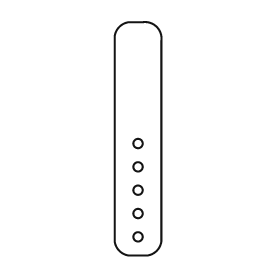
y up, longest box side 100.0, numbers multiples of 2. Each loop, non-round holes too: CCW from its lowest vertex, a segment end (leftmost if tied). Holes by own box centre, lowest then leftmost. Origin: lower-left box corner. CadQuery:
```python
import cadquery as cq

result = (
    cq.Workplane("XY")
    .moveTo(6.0, 0.0)
    .lineTo(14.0, 0.0)
    .threePointArc((18.0, 2.0), (20.0, 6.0))
    .lineTo(20.0, 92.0)
    .threePointArc((18.0, 98.0), (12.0, 100.0))
    .lineTo(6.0, 100.0)
    .threePointArc((2.0, 98.0), (0.0, 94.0))
    .lineTo(0.0, 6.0)
    .threePointArc((2.0, 2.0), (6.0, 0.0))
    .close()
    .moveTo(10.0, 8.0)
    .circle(2.0)
    .moveTo(10.0, 18.0)
    .circle(2.0)
    .moveTo(10.0, 28.0)
    .circle(2.0)
    .moveTo(10.0, 38.0)
    .circle(2.0)
    .moveTo(10.0, 48.0)
    .circle(2.0)
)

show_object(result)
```